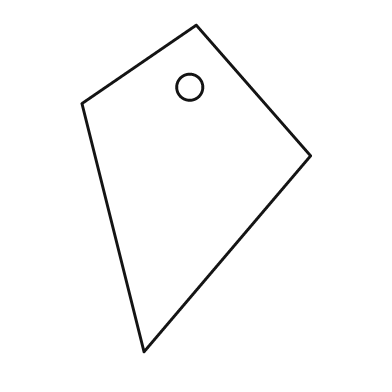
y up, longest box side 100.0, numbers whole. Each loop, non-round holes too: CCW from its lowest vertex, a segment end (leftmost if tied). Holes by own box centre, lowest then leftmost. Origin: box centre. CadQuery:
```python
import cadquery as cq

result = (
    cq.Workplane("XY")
    .moveTo(-16.0, -50.0)
    .lineTo(35.0, 10.0)
    .lineTo(0.0, 50.0)
    .lineTo(-35.0, 26.0)
    .close()
    .moveTo(-2.0, 31.0)
    .circle(4.0)
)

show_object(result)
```